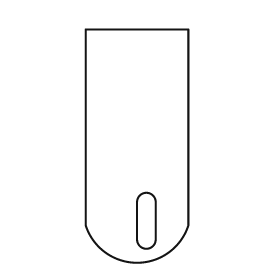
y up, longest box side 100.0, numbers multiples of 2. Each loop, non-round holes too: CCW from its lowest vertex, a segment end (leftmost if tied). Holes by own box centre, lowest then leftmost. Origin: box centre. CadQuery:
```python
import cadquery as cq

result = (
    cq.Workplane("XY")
    .moveTo(-22.0, -34.0)
    .threePointArc((0.0, -50.0), (22.0, -34.0))
    .lineTo(22.0, 50.0)
    .lineTo(-22.0, 50.0)
    .close()
    .moveTo(0.0, -40.0)
    .threePointArc((4.0, -44.0), (8.0, -40.0))
    .lineTo(8.0, -24.0)
    .threePointArc((4.0, -20.0), (0.0, -24.0))
    .close()
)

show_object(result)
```